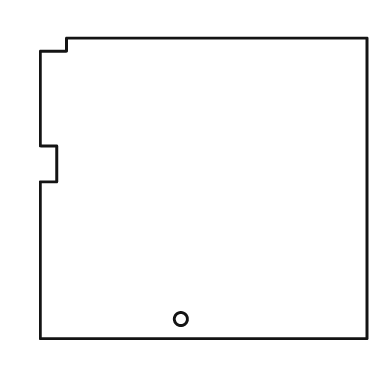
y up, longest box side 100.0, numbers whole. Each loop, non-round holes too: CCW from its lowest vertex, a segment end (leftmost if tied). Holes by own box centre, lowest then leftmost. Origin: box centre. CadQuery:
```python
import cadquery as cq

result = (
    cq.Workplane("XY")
    .moveTo(-50.0, -46.0)
    .lineTo(50.0, -46.0)
    .lineTo(50.0, 46.0)
    .lineTo(-42.0, 46.0)
    .lineTo(-42.0, 42.0)
    .lineTo(-50.0, 42.0)
    .lineTo(-50.0, 13.0)
    .lineTo(-45.0, 13.0)
    .lineTo(-45.0, 2.0)
    .lineTo(-50.0, 2.0)
    .close()
    .moveTo(-7.0, -40.0)
    .circle(2.0)
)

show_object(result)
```